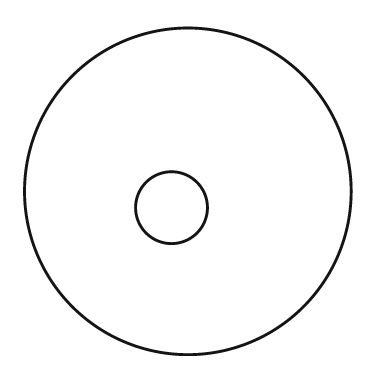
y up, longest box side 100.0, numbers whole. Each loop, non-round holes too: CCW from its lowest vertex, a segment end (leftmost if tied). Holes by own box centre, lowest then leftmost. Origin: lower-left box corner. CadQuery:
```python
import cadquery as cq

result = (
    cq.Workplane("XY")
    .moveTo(50.0, 50.0)
    .circle(50.0)
    .moveTo(45.0, 45.0)
    .circle(11.0)
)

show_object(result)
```